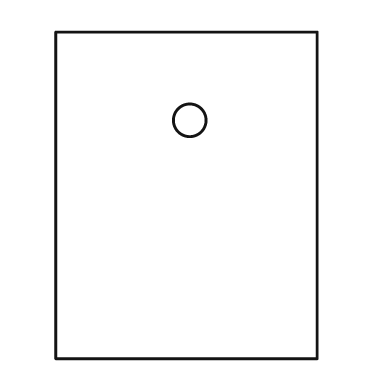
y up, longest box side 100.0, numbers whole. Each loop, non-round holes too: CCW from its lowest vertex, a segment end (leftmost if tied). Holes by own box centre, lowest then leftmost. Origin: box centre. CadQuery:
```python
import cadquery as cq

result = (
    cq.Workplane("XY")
    .moveTo(-40.0, -50.0)
    .lineTo(40.0, -50.0)
    .lineTo(40.0, 50.0)
    .lineTo(-40.0, 50.0)
    .close()
    .moveTo(1.0, 23.0)
    .circle(5.0)
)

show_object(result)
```